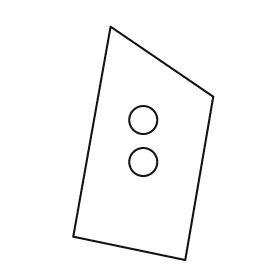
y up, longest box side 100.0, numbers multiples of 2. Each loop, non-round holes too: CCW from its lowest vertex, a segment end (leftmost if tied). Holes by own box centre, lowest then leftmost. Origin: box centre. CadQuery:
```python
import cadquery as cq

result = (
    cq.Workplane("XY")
    .moveTo(18.0, -50.0)
    .lineTo(30.0, 20.0)
    .lineTo(-14.0, 50.0)
    .lineTo(-30.0, -40.0)
    .close()
    .moveTo(0.0, -8.0)
    .circle(6.0)
    .moveTo(0.0, 10.0)
    .circle(6.0)
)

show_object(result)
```